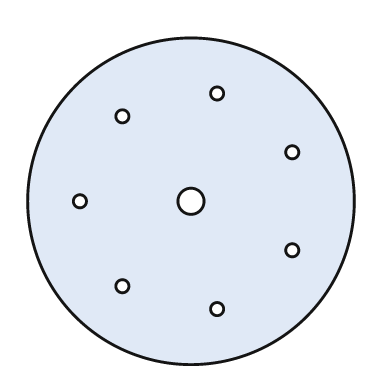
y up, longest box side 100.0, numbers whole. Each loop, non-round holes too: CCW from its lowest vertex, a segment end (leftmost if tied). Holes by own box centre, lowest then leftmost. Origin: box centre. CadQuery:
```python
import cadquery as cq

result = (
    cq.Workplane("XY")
    .moveTo(0.0, 0.0)
    .circle(50.0)
    .moveTo(8.0, -33.0)
    .circle(2.0)
    .moveTo(-21.0, -26.0)
    .circle(2.0)
    .moveTo(31.0, -15.0)
    .circle(2.0)
    .moveTo(-34.0, 0.0)
    .circle(2.0)
    .moveTo(0.0, 0.0)
    .circle(4.0)
    .moveTo(31.0, 15.0)
    .circle(2.0)
    .moveTo(-21.0, 26.0)
    .circle(2.0)
    .moveTo(8.0, 33.0)
    .circle(2.0)
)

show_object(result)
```